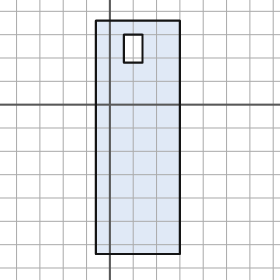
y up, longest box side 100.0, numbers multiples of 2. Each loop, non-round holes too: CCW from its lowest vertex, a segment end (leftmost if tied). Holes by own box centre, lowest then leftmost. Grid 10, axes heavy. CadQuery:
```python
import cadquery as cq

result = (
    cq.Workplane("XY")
    .moveTo(-6.0, -64.0)
    .lineTo(30.0, -64.0)
    .lineTo(30.0, 36.0)
    .lineTo(-6.0, 36.0)
    .close()
    .moveTo(6.0, 18.0)
    .lineTo(14.0, 18.0)
    .lineTo(14.0, 30.0)
    .lineTo(6.0, 30.0)
    .close()
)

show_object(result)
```